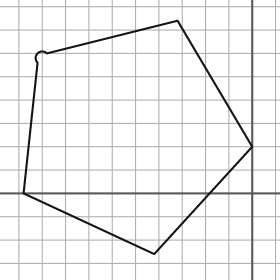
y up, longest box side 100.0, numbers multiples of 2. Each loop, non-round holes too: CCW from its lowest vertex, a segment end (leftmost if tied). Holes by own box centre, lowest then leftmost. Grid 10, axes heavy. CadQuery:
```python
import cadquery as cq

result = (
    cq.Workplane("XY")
    .moveTo(-42.0, -26.0)
    .lineTo(0.0, 20.0)
    .lineTo(-32.0, 74.0)
    .lineTo(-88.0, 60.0)
    .threePointArc((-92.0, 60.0), (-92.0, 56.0))
    .lineTo(-98.0, 0.0)
    .close()
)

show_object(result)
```